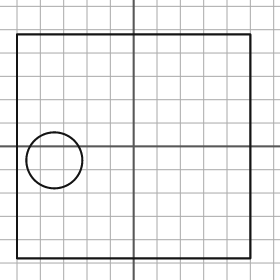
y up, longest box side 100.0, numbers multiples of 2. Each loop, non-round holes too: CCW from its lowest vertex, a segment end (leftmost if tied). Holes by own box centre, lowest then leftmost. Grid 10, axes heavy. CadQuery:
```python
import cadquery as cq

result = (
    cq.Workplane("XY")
    .moveTo(-50.0, -48.0)
    .lineTo(50.0, -48.0)
    .lineTo(50.0, 48.0)
    .lineTo(-50.0, 48.0)
    .close()
    .moveTo(-34.0, -6.0)
    .circle(12.0)
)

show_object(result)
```